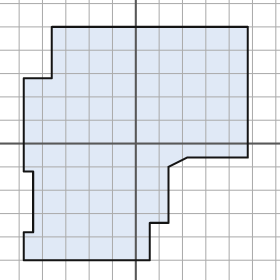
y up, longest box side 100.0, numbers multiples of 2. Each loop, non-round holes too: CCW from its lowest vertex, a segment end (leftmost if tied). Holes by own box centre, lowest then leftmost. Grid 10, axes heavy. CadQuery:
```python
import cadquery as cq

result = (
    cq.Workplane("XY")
    .moveTo(-48.0, -50.0)
    .lineTo(6.0, -50.0)
    .lineTo(6.0, -34.0)
    .lineTo(14.0, -34.0)
    .lineTo(14.0, -10.0)
    .lineTo(22.0, -6.0)
    .lineTo(48.0, -6.0)
    .lineTo(48.0, 50.0)
    .lineTo(-36.0, 50.0)
    .lineTo(-36.0, 28.0)
    .lineTo(-48.0, 28.0)
    .lineTo(-48.0, -12.0)
    .lineTo(-44.0, -12.0)
    .lineTo(-44.0, -38.0)
    .lineTo(-48.0, -38.0)
    .close()
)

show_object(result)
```